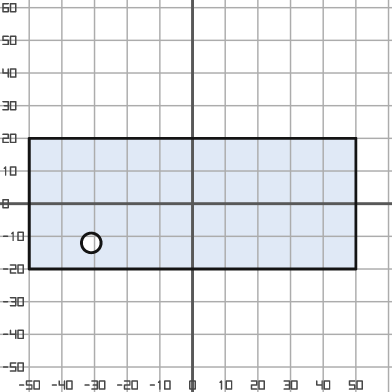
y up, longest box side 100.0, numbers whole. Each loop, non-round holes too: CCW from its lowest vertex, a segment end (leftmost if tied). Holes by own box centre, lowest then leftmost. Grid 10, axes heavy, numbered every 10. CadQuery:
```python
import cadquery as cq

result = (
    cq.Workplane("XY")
    .moveTo(-50.0, -20.0)
    .lineTo(50.0, -20.0)
    .lineTo(50.0, 20.0)
    .lineTo(-50.0, 20.0)
    .close()
    .moveTo(-31.0, -12.0)
    .circle(3.0)
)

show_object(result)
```